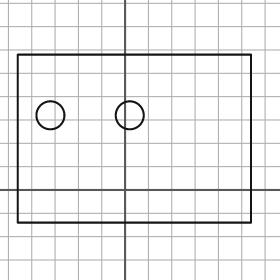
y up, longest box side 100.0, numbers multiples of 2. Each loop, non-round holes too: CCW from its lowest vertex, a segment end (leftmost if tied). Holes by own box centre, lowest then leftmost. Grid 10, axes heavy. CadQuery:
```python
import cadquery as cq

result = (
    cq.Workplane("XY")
    .moveTo(-46.0, -14.0)
    .lineTo(54.0, -14.0)
    .lineTo(54.0, 58.0)
    .lineTo(-46.0, 58.0)
    .close()
    .moveTo(-32.0, 32.0)
    .circle(6.0)
    .moveTo(2.0, 32.0)
    .circle(6.0)
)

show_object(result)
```